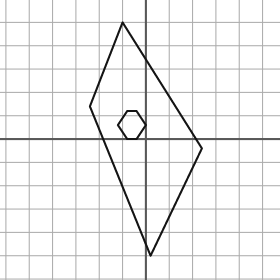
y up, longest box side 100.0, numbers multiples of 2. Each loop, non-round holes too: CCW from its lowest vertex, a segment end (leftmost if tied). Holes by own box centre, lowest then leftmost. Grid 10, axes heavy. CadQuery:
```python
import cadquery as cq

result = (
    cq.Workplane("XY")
    .moveTo(2.0, -50.0)
    .lineTo(24.0, -4.0)
    .lineTo(-10.0, 50.0)
    .lineTo(-24.0, 14.0)
    .close()
    .moveTo(-8.0, 0.0)
    .lineTo(-4.0, 0.0)
    .lineTo(0.0, 6.0)
    .lineTo(-4.0, 12.0)
    .lineTo(-8.0, 12.0)
    .lineTo(-12.0, 6.0)
    .close()
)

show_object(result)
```